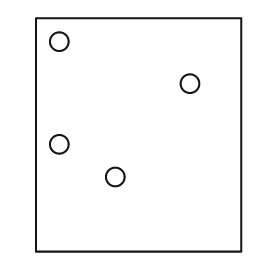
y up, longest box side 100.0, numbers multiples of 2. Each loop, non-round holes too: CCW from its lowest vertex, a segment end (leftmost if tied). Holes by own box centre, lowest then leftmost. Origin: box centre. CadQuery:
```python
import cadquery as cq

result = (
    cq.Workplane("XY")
    .moveTo(-44.0, -50.0)
    .lineTo(44.0, -50.0)
    .lineTo(44.0, 50.0)
    .lineTo(-44.0, 50.0)
    .close()
    .moveTo(-10.0, -18.0)
    .circle(4.0)
    .moveTo(-34.0, -4.0)
    .circle(4.0)
    .moveTo(22.0, 22.0)
    .circle(4.0)
    .moveTo(-34.0, 40.0)
    .circle(4.0)
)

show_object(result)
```